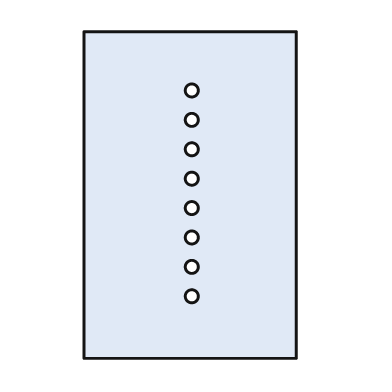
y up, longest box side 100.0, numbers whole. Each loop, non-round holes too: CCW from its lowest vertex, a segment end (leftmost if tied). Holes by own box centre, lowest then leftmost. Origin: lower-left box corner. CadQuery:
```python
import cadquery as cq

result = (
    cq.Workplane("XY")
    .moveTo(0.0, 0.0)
    .lineTo(65.0, 0.0)
    .lineTo(65.0, 100.0)
    .lineTo(0.0, 100.0)
    .close()
    .moveTo(33.0, 19.0)
    .circle(2.0)
    .moveTo(33.0, 28.0)
    .circle(2.0)
    .moveTo(33.0, 37.0)
    .circle(2.0)
    .moveTo(33.0, 46.0)
    .circle(2.0)
    .moveTo(33.0, 55.0)
    .circle(2.0)
    .moveTo(33.0, 64.0)
    .circle(2.0)
    .moveTo(33.0, 73.0)
    .circle(2.0)
    .moveTo(33.0, 82.0)
    .circle(2.0)
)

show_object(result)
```